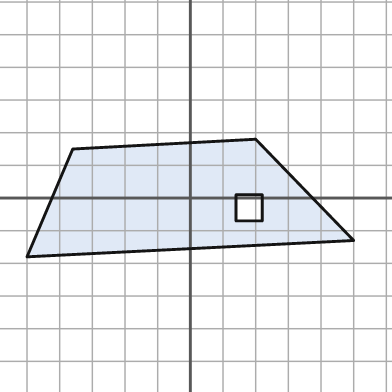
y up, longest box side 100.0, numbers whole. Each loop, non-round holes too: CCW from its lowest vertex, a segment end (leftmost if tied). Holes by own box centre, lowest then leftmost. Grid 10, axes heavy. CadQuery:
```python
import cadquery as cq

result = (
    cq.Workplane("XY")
    .moveTo(-50.0, -18.0)
    .lineTo(50.0, -13.0)
    .lineTo(20.0, 18.0)
    .lineTo(-36.0, 15.0)
    .close()
    .moveTo(14.0, -7.0)
    .lineTo(22.0, -7.0)
    .lineTo(22.0, 1.0)
    .lineTo(14.0, 1.0)
    .close()
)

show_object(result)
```